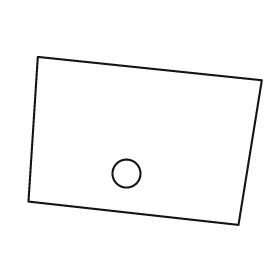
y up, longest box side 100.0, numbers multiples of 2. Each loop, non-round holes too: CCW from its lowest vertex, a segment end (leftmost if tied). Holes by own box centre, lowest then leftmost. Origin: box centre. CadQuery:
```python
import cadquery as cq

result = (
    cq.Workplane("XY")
    .moveTo(40.0, -36.0)
    .lineTo(50.0, 26.0)
    .lineTo(-46.0, 36.0)
    .lineTo(-50.0, -26.0)
    .close()
    .moveTo(-8.0, -14.0)
    .circle(6.0)
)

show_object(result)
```